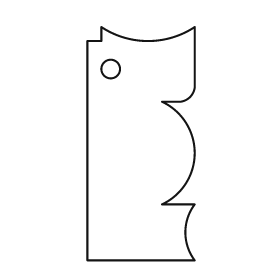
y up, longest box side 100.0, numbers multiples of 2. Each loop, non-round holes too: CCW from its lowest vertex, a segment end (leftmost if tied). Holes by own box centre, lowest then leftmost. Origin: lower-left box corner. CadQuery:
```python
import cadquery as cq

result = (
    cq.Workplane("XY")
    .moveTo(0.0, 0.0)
    .lineTo(46.0, 0.0)
    .threePointArc((42.0, 12.0), (46.0, 24.0))
    .lineTo(32.0, 24.0)
    .threePointArc((46.0, 46.0), (32.0, 68.0))
    .lineTo(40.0, 68.0)
    .threePointArc((44.0, 70.0), (46.0, 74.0))
    .lineTo(46.0, 100.0)
    .threePointArc((26.0, 94.0), (6.0, 100.0))
    .lineTo(6.0, 94.0)
    .lineTo(0.0, 94.0)
    .close()
    .moveTo(10.0, 82.0)
    .circle(4.0)
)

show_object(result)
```